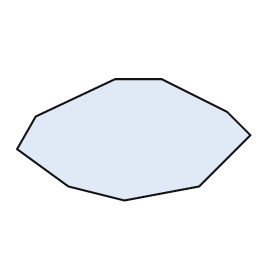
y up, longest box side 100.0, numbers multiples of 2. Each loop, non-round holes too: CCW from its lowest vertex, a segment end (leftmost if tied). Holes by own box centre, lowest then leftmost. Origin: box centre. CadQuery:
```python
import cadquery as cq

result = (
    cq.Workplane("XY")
    .moveTo(-4.0, -26.0)
    .lineTo(28.0, -20.0)
    .lineTo(50.0, 2.0)
    .lineTo(40.0, 12.0)
    .lineTo(12.0, 26.0)
    .lineTo(-8.0, 26.0)
    .lineTo(-42.0, 10.0)
    .lineTo(-50.0, -4.0)
    .lineTo(-28.0, -20.0)
    .close()
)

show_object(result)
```